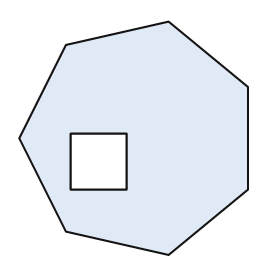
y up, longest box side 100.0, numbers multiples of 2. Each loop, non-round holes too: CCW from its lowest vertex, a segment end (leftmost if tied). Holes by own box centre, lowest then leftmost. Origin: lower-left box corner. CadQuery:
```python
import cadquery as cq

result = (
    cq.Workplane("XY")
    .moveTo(64.0, 0.0)
    .lineTo(98.0, 28.0)
    .lineTo(98.0, 72.0)
    .lineTo(64.0, 100.0)
    .lineTo(20.0, 90.0)
    .lineTo(0.0, 50.0)
    .lineTo(20.0, 10.0)
    .close()
    .moveTo(22.0, 28.0)
    .lineTo(46.0, 28.0)
    .lineTo(46.0, 52.0)
    .lineTo(22.0, 52.0)
    .close()
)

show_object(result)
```